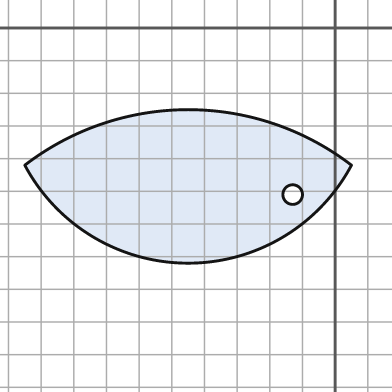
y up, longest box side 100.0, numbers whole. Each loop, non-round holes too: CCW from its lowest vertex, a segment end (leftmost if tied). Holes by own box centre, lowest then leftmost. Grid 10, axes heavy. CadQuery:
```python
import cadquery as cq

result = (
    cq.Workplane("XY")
    .moveTo(-95.0, -42.0)
    .threePointArc((-45.0, -72.0), (5.0, -42.0))
    .threePointArc((-45.0, -25.0), (-95.0, -42.0))
    .close()
    .moveTo(-13.0, -51.0)
    .circle(3.0)
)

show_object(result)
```